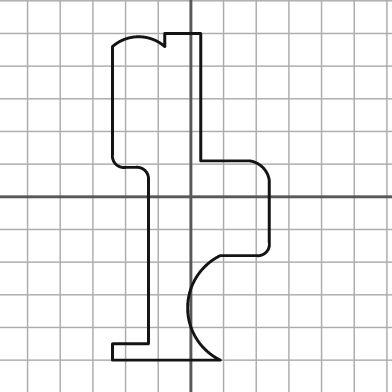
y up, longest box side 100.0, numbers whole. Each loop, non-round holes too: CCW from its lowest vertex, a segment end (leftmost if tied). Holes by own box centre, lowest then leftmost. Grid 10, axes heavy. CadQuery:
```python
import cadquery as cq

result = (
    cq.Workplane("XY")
    .moveTo(-24.0, -50.0)
    .lineTo(9.0, -50.0)
    .threePointArc((-1.0, -34.0), (9.0, -18.0))
    .lineTo(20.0, -18.0)
    .threePointArc((23.0, -17.0), (24.0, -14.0))
    .lineTo(24.0, 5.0)
    .threePointArc((22.0, 9.0), (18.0, 11.0))
    .lineTo(3.0, 11.0)
    .lineTo(3.0, 50.0)
    .lineTo(-8.0, 50.0)
    .lineTo(-8.0, 46.0)
    .threePointArc((-16.0, 49.0), (-24.0, 46.0))
    .lineTo(-24.0, 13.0)
    .threePointArc((-23.0, 10.0), (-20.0, 9.0))
    .lineTo(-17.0, 9.0)
    .threePointArc((-14.0, 8.0), (-13.0, 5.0))
    .lineTo(-13.0, -45.0)
    .lineTo(-24.0, -45.0)
    .close()
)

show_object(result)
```